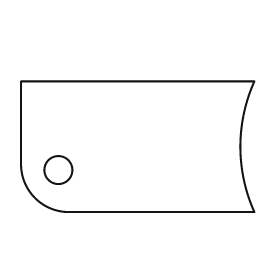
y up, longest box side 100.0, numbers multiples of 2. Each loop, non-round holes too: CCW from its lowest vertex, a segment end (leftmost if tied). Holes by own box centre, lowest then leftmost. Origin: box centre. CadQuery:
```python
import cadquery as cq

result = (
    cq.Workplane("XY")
    .moveTo(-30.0, -28.0)
    .lineTo(50.0, -28.0)
    .threePointArc((44.0, 0.0), (50.0, 28.0))
    .lineTo(-50.0, 28.0)
    .lineTo(-50.0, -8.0)
    .threePointArc((-44.0, -22.0), (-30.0, -28.0))
    .close()
    .moveTo(-34.0, -10.0)
    .circle(6.0)
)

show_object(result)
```